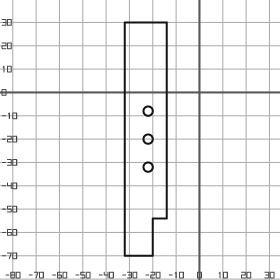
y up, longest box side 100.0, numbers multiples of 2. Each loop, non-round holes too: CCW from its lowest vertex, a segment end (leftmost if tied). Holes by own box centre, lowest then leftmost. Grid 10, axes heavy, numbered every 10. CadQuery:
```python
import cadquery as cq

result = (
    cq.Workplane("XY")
    .moveTo(-32.0, -70.0)
    .lineTo(-20.0, -70.0)
    .lineTo(-20.0, -54.0)
    .lineTo(-14.0, -54.0)
    .lineTo(-14.0, 30.0)
    .lineTo(-32.0, 30.0)
    .close()
    .moveTo(-22.0, -32.0)
    .circle(2.0)
    .moveTo(-22.0, -20.0)
    .circle(2.0)
    .moveTo(-22.0, -8.0)
    .circle(2.0)
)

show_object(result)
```